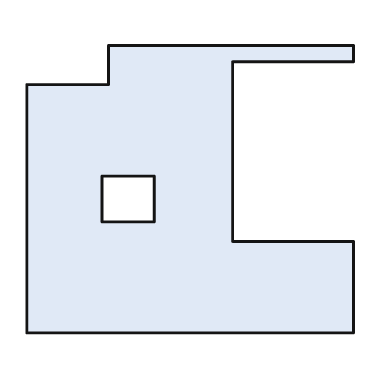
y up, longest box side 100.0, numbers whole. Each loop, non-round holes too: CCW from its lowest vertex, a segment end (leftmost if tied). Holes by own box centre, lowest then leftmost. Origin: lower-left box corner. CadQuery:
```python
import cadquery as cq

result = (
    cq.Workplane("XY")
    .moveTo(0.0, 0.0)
    .lineTo(100.0, 0.0)
    .lineTo(100.0, 28.0)
    .lineTo(63.0, 28.0)
    .lineTo(63.0, 83.0)
    .lineTo(100.0, 83.0)
    .lineTo(100.0, 88.0)
    .lineTo(25.0, 88.0)
    .lineTo(25.0, 76.0)
    .lineTo(0.0, 76.0)
    .close()
    .moveTo(23.0, 34.0)
    .lineTo(39.0, 34.0)
    .lineTo(39.0, 48.0)
    .lineTo(23.0, 48.0)
    .close()
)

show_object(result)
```